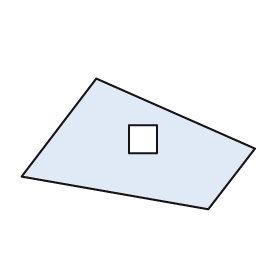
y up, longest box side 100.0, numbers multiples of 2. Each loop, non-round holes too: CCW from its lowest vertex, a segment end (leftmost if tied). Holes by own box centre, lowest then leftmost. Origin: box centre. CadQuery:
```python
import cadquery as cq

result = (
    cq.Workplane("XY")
    .moveTo(30.0, -28.0)
    .lineTo(50.0, -2.0)
    .lineTo(-18.0, 28.0)
    .lineTo(-50.0, -14.0)
    .close()
    .moveTo(-4.0, -4.0)
    .lineTo(8.0, -4.0)
    .lineTo(8.0, 8.0)
    .lineTo(-4.0, 8.0)
    .close()
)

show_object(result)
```